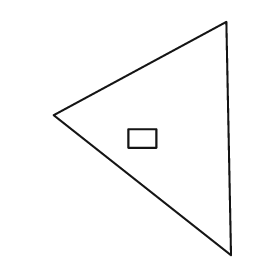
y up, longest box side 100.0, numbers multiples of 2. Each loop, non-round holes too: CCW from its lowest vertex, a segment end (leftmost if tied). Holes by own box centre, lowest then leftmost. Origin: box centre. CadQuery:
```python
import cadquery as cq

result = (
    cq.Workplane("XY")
    .moveTo(38.0, -50.0)
    .lineTo(36.0, 50.0)
    .lineTo(-38.0, 10.0)
    .close()
    .moveTo(-6.0, -4.0)
    .lineTo(6.0, -4.0)
    .lineTo(6.0, 4.0)
    .lineTo(-6.0, 4.0)
    .close()
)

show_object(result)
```